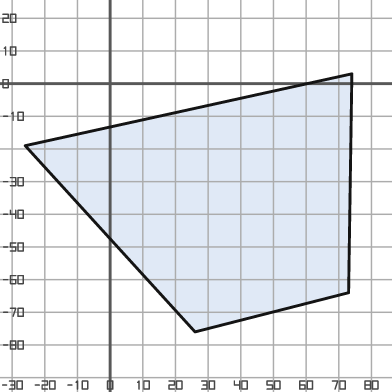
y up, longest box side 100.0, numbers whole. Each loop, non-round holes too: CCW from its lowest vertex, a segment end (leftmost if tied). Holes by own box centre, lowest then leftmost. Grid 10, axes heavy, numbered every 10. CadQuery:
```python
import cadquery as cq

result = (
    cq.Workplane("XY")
    .moveTo(26.0, -76.0)
    .lineTo(73.0, -64.0)
    .lineTo(74.0, 3.0)
    .lineTo(-26.0, -19.0)
    .close()
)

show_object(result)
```